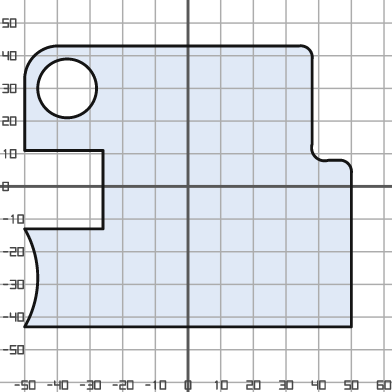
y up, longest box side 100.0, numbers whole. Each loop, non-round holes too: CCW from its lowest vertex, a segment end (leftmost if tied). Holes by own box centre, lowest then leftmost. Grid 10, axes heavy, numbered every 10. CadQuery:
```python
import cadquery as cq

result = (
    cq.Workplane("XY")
    .moveTo(-50.0, -43.0)
    .lineTo(50.0, -43.0)
    .lineTo(50.0, 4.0)
    .threePointArc((49.0, 7.0), (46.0, 8.0))
    .lineTo(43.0, 8.0)
    .threePointArc((39.0, 9.0), (38.0, 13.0))
    .lineTo(38.0, 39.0)
    .threePointArc((37.0, 42.0), (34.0, 43.0))
    .lineTo(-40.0, 43.0)
    .threePointArc((-47.0, 40.0), (-50.0, 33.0))
    .lineTo(-50.0, 11.0)
    .lineTo(-26.0, 11.0)
    .lineTo(-26.0, -13.0)
    .lineTo(-50.0, -13.0)
    .threePointArc((-46.0, -28.0), (-50.0, -43.0))
    .close()
    .moveTo(-37.0, 30.0)
    .circle(9.0)
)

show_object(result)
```